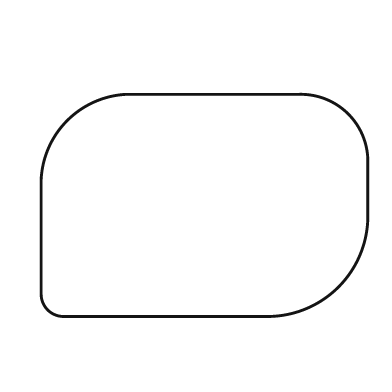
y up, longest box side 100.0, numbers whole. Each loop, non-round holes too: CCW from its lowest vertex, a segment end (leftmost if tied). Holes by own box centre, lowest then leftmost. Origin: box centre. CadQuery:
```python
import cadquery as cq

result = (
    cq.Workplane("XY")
    .moveTo(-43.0, -34.0)
    .lineTo(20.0, -34.0)
    .threePointArc((41.0, -25.0), (50.0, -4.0))
    .lineTo(50.0, 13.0)
    .threePointArc((44.0, 28.0), (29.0, 34.0))
    .lineTo(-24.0, 34.0)
    .threePointArc((-42.0, 26.0), (-50.0, 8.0))
    .lineTo(-50.0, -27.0)
    .threePointArc((-48.0, -32.0), (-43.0, -34.0))
    .close()
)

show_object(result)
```